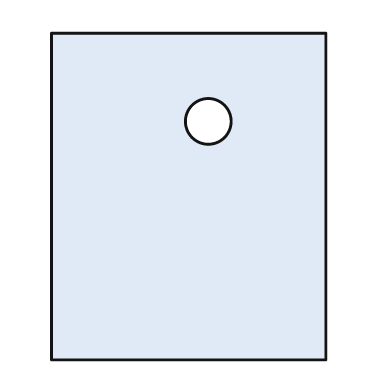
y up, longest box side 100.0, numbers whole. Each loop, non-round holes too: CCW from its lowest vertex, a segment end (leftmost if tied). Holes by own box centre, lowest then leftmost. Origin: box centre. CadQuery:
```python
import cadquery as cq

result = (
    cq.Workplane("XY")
    .moveTo(-42.0, -50.0)
    .lineTo(42.0, -50.0)
    .lineTo(42.0, 50.0)
    .lineTo(-42.0, 50.0)
    .close()
    .moveTo(6.0, 23.0)
    .circle(7.0)
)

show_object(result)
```